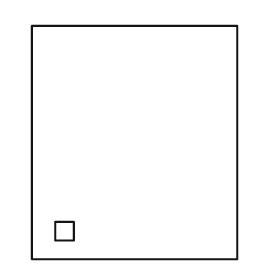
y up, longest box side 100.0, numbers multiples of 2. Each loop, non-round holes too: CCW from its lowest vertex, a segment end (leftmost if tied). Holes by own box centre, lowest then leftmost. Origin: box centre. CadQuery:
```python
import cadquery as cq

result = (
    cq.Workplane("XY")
    .moveTo(-44.0, -50.0)
    .lineTo(44.0, -50.0)
    .lineTo(44.0, 50.0)
    .lineTo(-44.0, 50.0)
    .close()
    .moveTo(-34.0, -42.0)
    .lineTo(-26.0, -42.0)
    .lineTo(-26.0, -34.0)
    .lineTo(-34.0, -34.0)
    .close()
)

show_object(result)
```